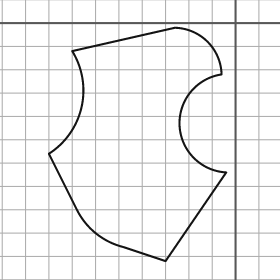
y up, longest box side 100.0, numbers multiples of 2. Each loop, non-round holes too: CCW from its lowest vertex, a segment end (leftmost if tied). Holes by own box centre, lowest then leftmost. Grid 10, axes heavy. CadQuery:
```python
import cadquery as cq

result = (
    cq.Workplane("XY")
    .moveTo(-30.0, -102.0)
    .lineTo(-4.0, -64.0)
    .threePointArc((-24.0, -44.0), (-6.0, -22.0))
    .threePointArc((-12.0, -8.0), (-26.0, -2.0))
    .lineTo(-70.0, -12.0)
    .threePointArc((-66.0, -36.0), (-80.0, -56.0))
    .lineTo(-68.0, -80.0)
    .threePointArc((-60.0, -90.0), (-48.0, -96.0))
    .close()
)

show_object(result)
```